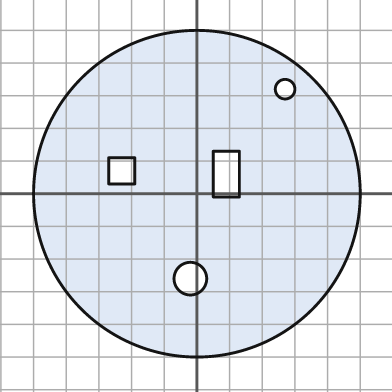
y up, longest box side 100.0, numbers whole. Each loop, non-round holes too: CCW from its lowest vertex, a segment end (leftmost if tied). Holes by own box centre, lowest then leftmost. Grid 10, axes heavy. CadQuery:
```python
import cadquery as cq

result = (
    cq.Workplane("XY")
    .moveTo(0.0, 0.0)
    .circle(50.0)
    .moveTo(-2.0, -26.0)
    .circle(5.0)
    .moveTo(5.0, -1.0)
    .lineTo(13.0, -1.0)
    .lineTo(13.0, 13.0)
    .lineTo(5.0, 13.0)
    .close()
    .moveTo(-27.0, 3.0)
    .lineTo(-19.0, 3.0)
    .lineTo(-19.0, 11.0)
    .lineTo(-27.0, 11.0)
    .close()
    .moveTo(27.0, 32.0)
    .circle(3.0)
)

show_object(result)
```